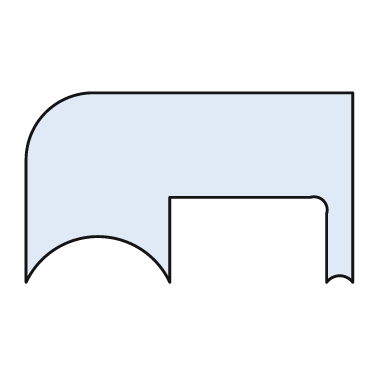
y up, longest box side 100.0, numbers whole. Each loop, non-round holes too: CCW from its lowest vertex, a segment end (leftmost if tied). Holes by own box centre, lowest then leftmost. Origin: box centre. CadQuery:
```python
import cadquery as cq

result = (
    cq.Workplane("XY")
    .moveTo(-50.0, -29.0)
    .threePointArc((-28.0, -15.0), (-6.0, -29.0))
    .lineTo(-6.0, -3.0)
    .lineTo(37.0, -3.0)
    .threePointArc((41.0, -4.0), (42.0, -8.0))
    .lineTo(42.0, -29.0)
    .threePointArc((46.0, -27.0), (50.0, -29.0))
    .lineTo(50.0, 29.0)
    .lineTo(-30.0, 29.0)
    .threePointArc((-44.0, 23.0), (-50.0, 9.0))
    .close()
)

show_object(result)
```